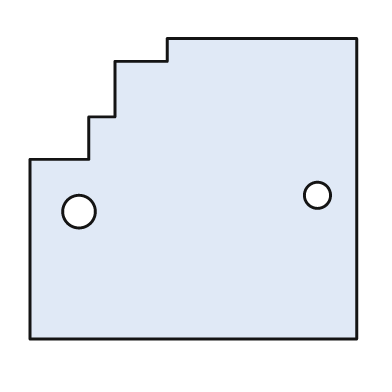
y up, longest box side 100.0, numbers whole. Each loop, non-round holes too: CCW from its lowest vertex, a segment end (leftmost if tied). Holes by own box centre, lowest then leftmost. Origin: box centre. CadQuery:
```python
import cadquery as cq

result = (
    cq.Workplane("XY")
    .moveTo(-50.0, -46.0)
    .lineTo(50.0, -46.0)
    .lineTo(50.0, 46.0)
    .lineTo(-8.0, 46.0)
    .lineTo(-8.0, 39.0)
    .lineTo(-24.0, 39.0)
    .lineTo(-24.0, 22.0)
    .lineTo(-32.0, 22.0)
    .lineTo(-32.0, 9.0)
    .lineTo(-50.0, 9.0)
    .close()
    .moveTo(-35.0, -7.0)
    .circle(5.0)
    .moveTo(38.0, -2.0)
    .circle(4.0)
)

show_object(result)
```